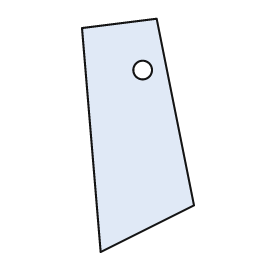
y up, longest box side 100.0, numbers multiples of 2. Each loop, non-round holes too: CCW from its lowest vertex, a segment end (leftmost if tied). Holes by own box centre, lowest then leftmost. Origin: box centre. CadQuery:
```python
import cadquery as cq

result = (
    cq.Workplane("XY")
    .moveTo(-16.0, -50.0)
    .lineTo(24.0, -30.0)
    .lineTo(8.0, 50.0)
    .lineTo(-24.0, 46.0)
    .close()
    .moveTo(2.0, 28.0)
    .circle(4.0)
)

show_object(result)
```